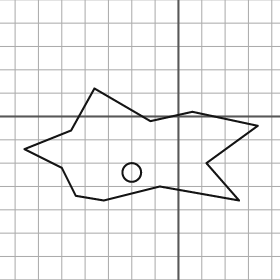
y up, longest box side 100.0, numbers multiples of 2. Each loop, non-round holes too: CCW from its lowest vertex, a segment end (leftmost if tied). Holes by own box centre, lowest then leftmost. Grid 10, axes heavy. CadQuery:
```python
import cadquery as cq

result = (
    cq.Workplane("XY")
    .moveTo(-32.0, -36.0)
    .lineTo(-8.0, -30.0)
    .lineTo(26.0, -36.0)
    .lineTo(12.0, -20.0)
    .lineTo(34.0, -4.0)
    .lineTo(6.0, 2.0)
    .lineTo(-12.0, -2.0)
    .lineTo(-36.0, 12.0)
    .lineTo(-46.0, -6.0)
    .lineTo(-66.0, -14.0)
    .lineTo(-50.0, -22.0)
    .lineTo(-44.0, -34.0)
    .close()
    .moveTo(-20.0, -24.0)
    .circle(4.0)
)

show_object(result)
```